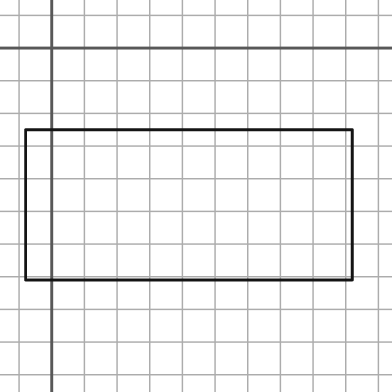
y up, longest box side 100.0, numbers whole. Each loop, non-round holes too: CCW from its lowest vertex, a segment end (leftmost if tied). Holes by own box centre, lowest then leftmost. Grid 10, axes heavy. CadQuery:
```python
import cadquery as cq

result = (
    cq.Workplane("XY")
    .moveTo(-8.0, -71.0)
    .lineTo(92.0, -71.0)
    .lineTo(92.0, -25.0)
    .lineTo(-8.0, -25.0)
    .close()
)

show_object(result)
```